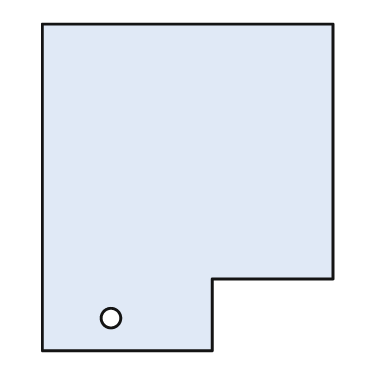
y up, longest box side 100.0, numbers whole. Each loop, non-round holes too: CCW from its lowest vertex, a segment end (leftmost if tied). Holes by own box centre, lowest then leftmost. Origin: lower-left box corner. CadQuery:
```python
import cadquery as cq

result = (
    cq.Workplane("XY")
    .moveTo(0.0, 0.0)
    .lineTo(52.0, 0.0)
    .lineTo(52.0, 22.0)
    .lineTo(89.0, 22.0)
    .lineTo(89.0, 100.0)
    .lineTo(0.0, 100.0)
    .close()
    .moveTo(21.0, 10.0)
    .circle(3.0)
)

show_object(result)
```